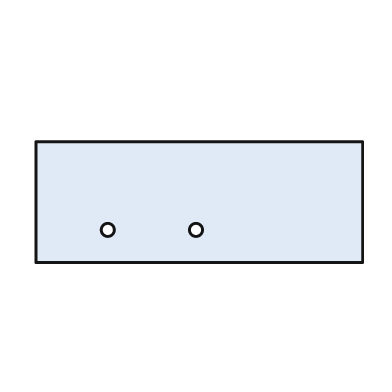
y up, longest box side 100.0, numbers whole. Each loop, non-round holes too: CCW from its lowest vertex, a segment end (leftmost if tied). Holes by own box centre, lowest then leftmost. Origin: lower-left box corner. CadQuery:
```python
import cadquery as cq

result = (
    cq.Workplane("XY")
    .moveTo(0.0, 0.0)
    .lineTo(100.0, 0.0)
    .lineTo(100.0, 37.0)
    .lineTo(0.0, 37.0)
    .close()
    .moveTo(22.0, 10.0)
    .circle(2.0)
    .moveTo(49.0, 10.0)
    .circle(2.0)
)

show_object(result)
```